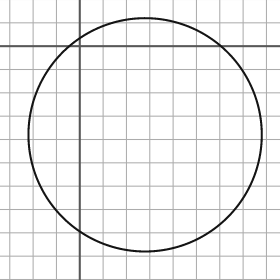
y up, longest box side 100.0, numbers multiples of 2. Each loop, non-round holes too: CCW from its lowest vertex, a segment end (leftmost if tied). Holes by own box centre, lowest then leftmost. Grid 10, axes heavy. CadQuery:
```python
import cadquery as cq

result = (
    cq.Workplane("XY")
    .moveTo(28.0, -38.0)
    .circle(50.0)
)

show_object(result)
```